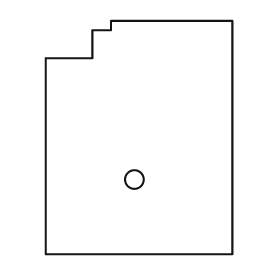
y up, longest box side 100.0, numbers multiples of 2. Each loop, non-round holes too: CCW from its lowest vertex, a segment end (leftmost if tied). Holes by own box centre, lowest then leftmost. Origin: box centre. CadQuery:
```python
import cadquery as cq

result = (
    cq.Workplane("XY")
    .moveTo(-40.0, -50.0)
    .lineTo(40.0, -50.0)
    .lineTo(40.0, 50.0)
    .lineTo(-12.0, 50.0)
    .lineTo(-12.0, 46.0)
    .lineTo(-20.0, 46.0)
    .lineTo(-20.0, 34.0)
    .lineTo(-40.0, 34.0)
    .close()
    .moveTo(-2.0, -18.0)
    .circle(4.0)
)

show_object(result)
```